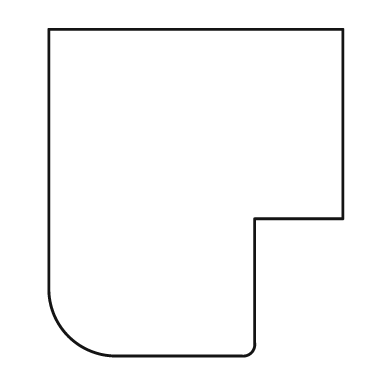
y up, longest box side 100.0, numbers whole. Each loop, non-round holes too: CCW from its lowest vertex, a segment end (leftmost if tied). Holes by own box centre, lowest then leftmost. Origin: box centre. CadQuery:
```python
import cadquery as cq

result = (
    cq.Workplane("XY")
    .moveTo(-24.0, -50.0)
    .lineTo(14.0, -50.0)
    .threePointArc((17.0, -49.0), (18.0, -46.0))
    .lineTo(18.0, -8.0)
    .lineTo(45.0, -8.0)
    .lineTo(45.0, 50.0)
    .lineTo(-45.0, 50.0)
    .lineTo(-45.0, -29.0)
    .threePointArc((-39.0, -44.0), (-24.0, -50.0))
    .close()
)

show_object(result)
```